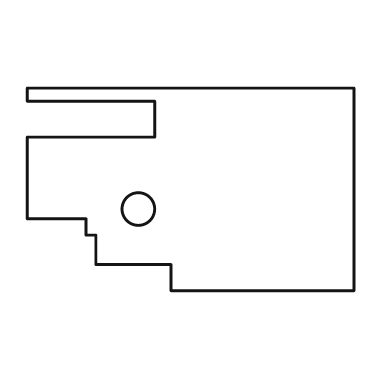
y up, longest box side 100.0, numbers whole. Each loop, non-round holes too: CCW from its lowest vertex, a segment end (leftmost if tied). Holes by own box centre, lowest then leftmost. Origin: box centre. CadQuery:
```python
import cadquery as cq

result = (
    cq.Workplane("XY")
    .moveTo(-6.0, -31.0)
    .lineTo(50.0, -31.0)
    .lineTo(50.0, 31.0)
    .lineTo(-50.0, 31.0)
    .lineTo(-50.0, 27.0)
    .lineTo(-11.0, 27.0)
    .lineTo(-11.0, 16.0)
    .lineTo(-50.0, 16.0)
    .lineTo(-50.0, -9.0)
    .lineTo(-32.0, -9.0)
    .lineTo(-32.0, -14.0)
    .lineTo(-29.0, -14.0)
    .lineTo(-29.0, -23.0)
    .lineTo(-6.0, -23.0)
    .close()
    .moveTo(-16.0, -6.0)
    .circle(5.0)
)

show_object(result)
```